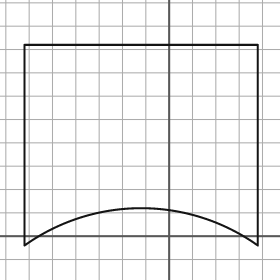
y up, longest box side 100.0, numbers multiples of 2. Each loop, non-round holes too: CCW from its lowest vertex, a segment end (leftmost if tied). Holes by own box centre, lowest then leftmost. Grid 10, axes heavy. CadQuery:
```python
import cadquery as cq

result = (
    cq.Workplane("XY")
    .moveTo(-62.0, -4.0)
    .threePointArc((-12.0, 12.0), (38.0, -4.0))
    .lineTo(38.0, 82.0)
    .lineTo(-62.0, 82.0)
    .close()
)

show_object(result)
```